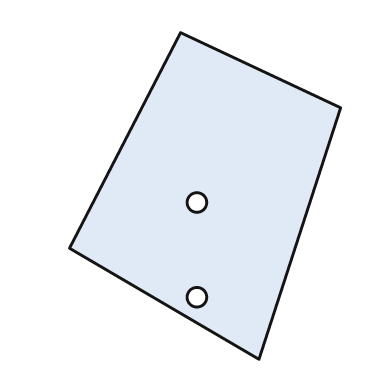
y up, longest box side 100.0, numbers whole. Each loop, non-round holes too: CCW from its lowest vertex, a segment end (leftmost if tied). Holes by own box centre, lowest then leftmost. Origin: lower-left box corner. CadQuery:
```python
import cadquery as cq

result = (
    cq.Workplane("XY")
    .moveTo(58.0, 0.0)
    .lineTo(83.0, 77.0)
    .lineTo(34.0, 100.0)
    .lineTo(0.0, 34.0)
    .close()
    .moveTo(39.0, 19.0)
    .circle(3.0)
    .moveTo(39.0, 48.0)
    .circle(3.0)
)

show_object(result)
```